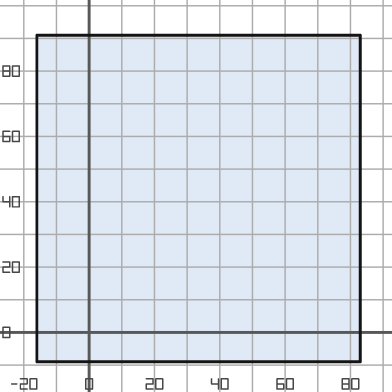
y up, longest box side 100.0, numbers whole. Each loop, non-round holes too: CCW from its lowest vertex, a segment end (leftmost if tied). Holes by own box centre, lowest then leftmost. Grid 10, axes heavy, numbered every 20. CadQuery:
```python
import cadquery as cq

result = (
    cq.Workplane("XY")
    .moveTo(-16.0, -9.0)
    .lineTo(83.0, -9.0)
    .lineTo(83.0, 91.0)
    .lineTo(-16.0, 91.0)
    .close()
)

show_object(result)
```